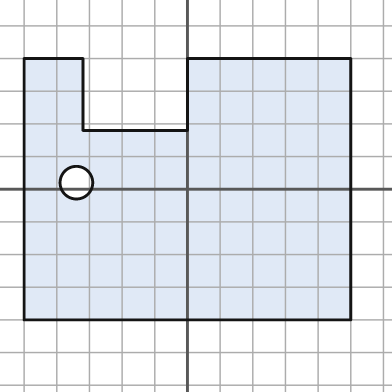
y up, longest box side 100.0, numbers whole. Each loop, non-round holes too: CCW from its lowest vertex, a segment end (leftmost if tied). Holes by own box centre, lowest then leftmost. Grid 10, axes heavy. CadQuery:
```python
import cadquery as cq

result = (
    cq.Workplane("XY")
    .moveTo(-50.0, -40.0)
    .lineTo(50.0, -40.0)
    .lineTo(50.0, 40.0)
    .lineTo(0.0, 40.0)
    .lineTo(0.0, 18.0)
    .lineTo(-32.0, 18.0)
    .lineTo(-32.0, 40.0)
    .lineTo(-50.0, 40.0)
    .close()
    .moveTo(-34.0, 2.0)
    .circle(5.0)
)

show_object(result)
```